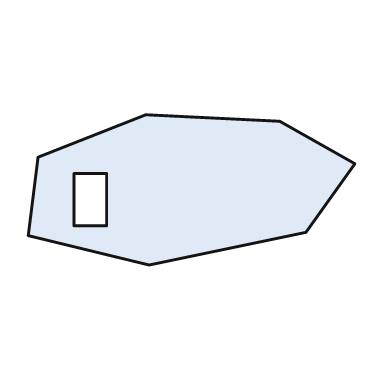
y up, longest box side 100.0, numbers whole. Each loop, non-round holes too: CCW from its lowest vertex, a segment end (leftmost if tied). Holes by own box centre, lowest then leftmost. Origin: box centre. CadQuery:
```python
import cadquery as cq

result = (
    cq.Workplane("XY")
    .moveTo(-13.0, -23.0)
    .lineTo(35.0, -13.0)
    .lineTo(50.0, 8.0)
    .lineTo(27.0, 21.0)
    .lineTo(-14.0, 23.0)
    .lineTo(-47.0, 10.0)
    .lineTo(-50.0, -14.0)
    .close()
    .moveTo(-36.0, -11.0)
    .lineTo(-26.0, -11.0)
    .lineTo(-26.0, 5.0)
    .lineTo(-36.0, 5.0)
    .close()
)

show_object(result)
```